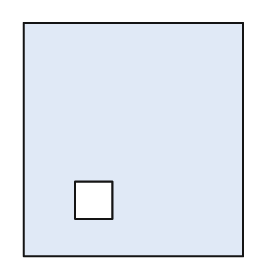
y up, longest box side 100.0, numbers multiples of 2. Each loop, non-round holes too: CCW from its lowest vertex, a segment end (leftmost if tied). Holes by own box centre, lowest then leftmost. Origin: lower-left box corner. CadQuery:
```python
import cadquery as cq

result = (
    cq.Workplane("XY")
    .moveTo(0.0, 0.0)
    .lineTo(94.0, 0.0)
    .lineTo(94.0, 100.0)
    .lineTo(0.0, 100.0)
    .close()
    .moveTo(22.0, 16.0)
    .lineTo(38.0, 16.0)
    .lineTo(38.0, 32.0)
    .lineTo(22.0, 32.0)
    .close()
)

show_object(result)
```